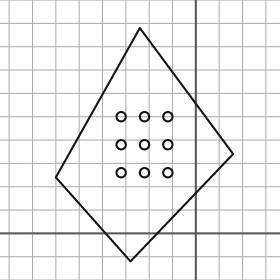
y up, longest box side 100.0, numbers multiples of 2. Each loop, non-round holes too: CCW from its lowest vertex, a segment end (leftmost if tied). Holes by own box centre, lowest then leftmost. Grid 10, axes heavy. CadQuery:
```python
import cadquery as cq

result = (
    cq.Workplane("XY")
    .moveTo(-28.0, -12.0)
    .lineTo(16.0, 34.0)
    .lineTo(-24.0, 88.0)
    .lineTo(-60.0, 24.0)
    .close()
    .moveTo(-32.0, 26.0)
    .circle(2.0)
    .moveTo(-22.0, 26.0)
    .circle(2.0)
    .moveTo(-12.0, 26.0)
    .circle(2.0)
    .moveTo(-32.0, 38.0)
    .circle(2.0)
    .moveTo(-22.0, 38.0)
    .circle(2.0)
    .moveTo(-12.0, 38.0)
    .circle(2.0)
    .moveTo(-32.0, 50.0)
    .circle(2.0)
    .moveTo(-22.0, 50.0)
    .circle(2.0)
    .moveTo(-12.0, 50.0)
    .circle(2.0)
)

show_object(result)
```